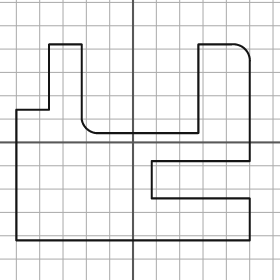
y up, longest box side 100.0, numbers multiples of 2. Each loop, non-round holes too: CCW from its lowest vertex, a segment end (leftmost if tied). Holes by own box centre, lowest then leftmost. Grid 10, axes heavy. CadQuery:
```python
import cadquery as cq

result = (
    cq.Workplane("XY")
    .moveTo(-50.0, -42.0)
    .lineTo(50.0, -42.0)
    .lineTo(50.0, -24.0)
    .lineTo(8.0, -24.0)
    .lineTo(8.0, -8.0)
    .lineTo(50.0, -8.0)
    .lineTo(50.0, 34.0)
    .threePointArc((48.0, 40.0), (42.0, 42.0))
    .lineTo(28.0, 42.0)
    .lineTo(28.0, 4.0)
    .lineTo(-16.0, 4.0)
    .threePointArc((-20.0, 6.0), (-22.0, 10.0))
    .lineTo(-22.0, 42.0)
    .lineTo(-36.0, 42.0)
    .lineTo(-36.0, 14.0)
    .lineTo(-50.0, 14.0)
    .close()
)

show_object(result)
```